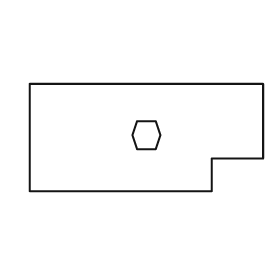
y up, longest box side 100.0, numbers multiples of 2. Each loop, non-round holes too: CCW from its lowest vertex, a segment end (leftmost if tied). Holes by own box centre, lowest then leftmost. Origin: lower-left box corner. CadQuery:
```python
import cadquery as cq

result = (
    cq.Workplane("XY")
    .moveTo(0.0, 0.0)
    .lineTo(78.0, 0.0)
    .lineTo(78.0, 14.0)
    .lineTo(100.0, 14.0)
    .lineTo(100.0, 46.0)
    .lineTo(0.0, 46.0)
    .close()
    .moveTo(46.0, 18.0)
    .lineTo(54.0, 18.0)
    .lineTo(56.0, 24.0)
    .lineTo(54.0, 30.0)
    .lineTo(46.0, 30.0)
    .lineTo(44.0, 24.0)
    .close()
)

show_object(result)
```